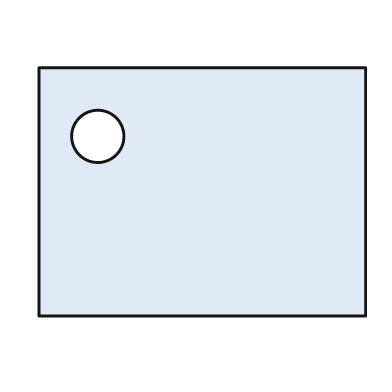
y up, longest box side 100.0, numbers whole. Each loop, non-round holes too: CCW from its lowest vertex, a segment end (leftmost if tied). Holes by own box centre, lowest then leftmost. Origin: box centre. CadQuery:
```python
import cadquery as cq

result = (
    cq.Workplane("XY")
    .moveTo(-50.0, -38.0)
    .lineTo(50.0, -38.0)
    .lineTo(50.0, 38.0)
    .lineTo(-50.0, 38.0)
    .close()
    .moveTo(-32.0, 17.0)
    .circle(8.0)
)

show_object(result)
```